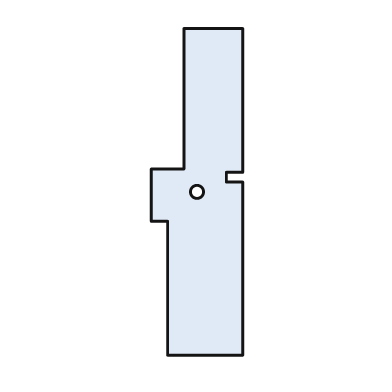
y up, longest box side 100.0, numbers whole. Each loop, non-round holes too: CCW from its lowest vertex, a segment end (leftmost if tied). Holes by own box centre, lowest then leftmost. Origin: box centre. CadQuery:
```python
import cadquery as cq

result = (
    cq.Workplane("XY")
    .moveTo(-9.0, -50.0)
    .lineTo(14.0, -50.0)
    .lineTo(14.0, 3.0)
    .lineTo(9.0, 3.0)
    .lineTo(9.0, 6.0)
    .lineTo(14.0, 6.0)
    .lineTo(14.0, 50.0)
    .lineTo(-4.0, 50.0)
    .lineTo(-4.0, 7.0)
    .lineTo(-14.0, 7.0)
    .lineTo(-14.0, -9.0)
    .lineTo(-9.0, -9.0)
    .close()
    .moveTo(0.0, 0.0)
    .circle(2.0)
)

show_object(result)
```